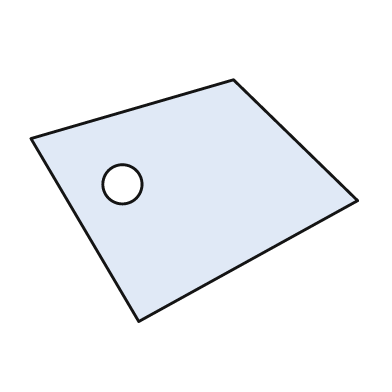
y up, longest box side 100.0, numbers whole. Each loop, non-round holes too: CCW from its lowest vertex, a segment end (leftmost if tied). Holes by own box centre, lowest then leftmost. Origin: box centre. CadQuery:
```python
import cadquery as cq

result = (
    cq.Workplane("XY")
    .moveTo(-17.0, -37.0)
    .lineTo(50.0, 0.0)
    .lineTo(12.0, 37.0)
    .lineTo(-50.0, 19.0)
    .close()
    .moveTo(-22.0, 5.0)
    .circle(6.0)
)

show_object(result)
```